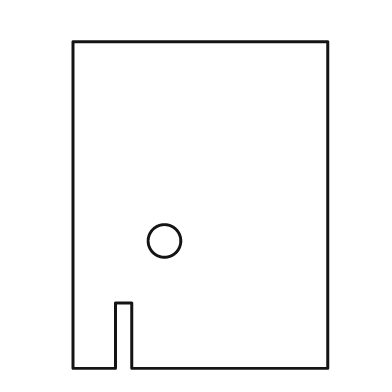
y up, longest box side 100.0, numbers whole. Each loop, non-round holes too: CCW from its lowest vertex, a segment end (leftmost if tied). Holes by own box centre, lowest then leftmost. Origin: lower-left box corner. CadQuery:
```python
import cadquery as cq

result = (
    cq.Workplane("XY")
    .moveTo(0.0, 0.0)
    .lineTo(13.0, 0.0)
    .lineTo(13.0, 20.0)
    .lineTo(18.0, 20.0)
    .lineTo(18.0, 0.0)
    .lineTo(78.0, 0.0)
    .lineTo(78.0, 100.0)
    .lineTo(0.0, 100.0)
    .close()
    .moveTo(28.0, 39.0)
    .circle(5.0)
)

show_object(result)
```